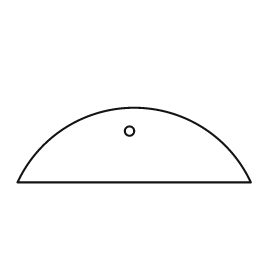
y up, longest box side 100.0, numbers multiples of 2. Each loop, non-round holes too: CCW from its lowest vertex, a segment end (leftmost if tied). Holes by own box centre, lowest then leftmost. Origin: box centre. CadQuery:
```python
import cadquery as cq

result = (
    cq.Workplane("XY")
    .moveTo(-50.0, -16.0)
    .lineTo(50.0, -16.0)
    .threePointArc((0.0, 16.0), (-50.0, -16.0))
    .close()
    .moveTo(-2.0, 6.0)
    .circle(2.0)
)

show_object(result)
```